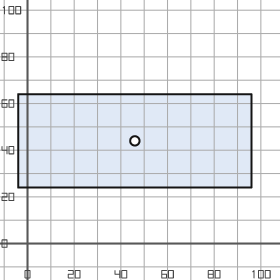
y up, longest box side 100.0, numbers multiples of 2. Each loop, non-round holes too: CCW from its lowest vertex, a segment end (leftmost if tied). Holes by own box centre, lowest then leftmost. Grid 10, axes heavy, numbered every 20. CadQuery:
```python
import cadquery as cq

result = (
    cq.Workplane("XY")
    .moveTo(-4.0, 24.0)
    .lineTo(96.0, 24.0)
    .lineTo(96.0, 64.0)
    .lineTo(-4.0, 64.0)
    .close()
    .moveTo(46.0, 44.0)
    .circle(2.0)
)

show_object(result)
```